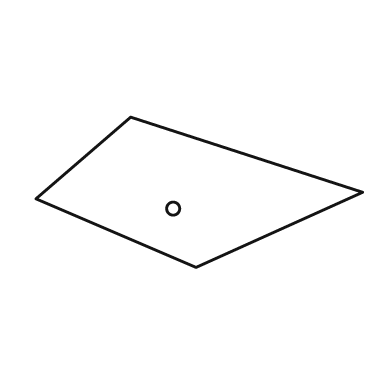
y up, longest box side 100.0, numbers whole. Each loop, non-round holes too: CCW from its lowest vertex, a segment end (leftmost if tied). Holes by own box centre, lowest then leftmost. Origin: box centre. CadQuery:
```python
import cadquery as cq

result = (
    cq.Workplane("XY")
    .moveTo(-1.0, -23.0)
    .lineTo(50.0, 0.0)
    .lineTo(-21.0, 23.0)
    .lineTo(-50.0, -2.0)
    .close()
    .moveTo(-8.0, -5.0)
    .circle(2.0)
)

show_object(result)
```